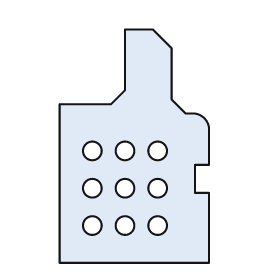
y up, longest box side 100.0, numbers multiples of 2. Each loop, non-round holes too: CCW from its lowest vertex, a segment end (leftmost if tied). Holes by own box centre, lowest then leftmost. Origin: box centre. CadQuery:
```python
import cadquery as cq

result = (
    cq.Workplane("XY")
    .moveTo(-32.0, -50.0)
    .lineTo(32.0, -50.0)
    .lineTo(32.0, -20.0)
    .lineTo(26.0, -20.0)
    .lineTo(26.0, -8.0)
    .lineTo(32.0, -8.0)
    .lineTo(32.0, 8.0)
    .threePointArc((30.0, 12.0), (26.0, 14.0))
    .lineTo(22.0, 14.0)
    .lineTo(16.0, 20.0)
    .lineTo(16.0, 42.0)
    .lineTo(8.0, 50.0)
    .lineTo(-4.0, 50.0)
    .lineTo(-4.0, 24.0)
    .lineTo(-10.0, 18.0)
    .lineTo(-32.0, 18.0)
    .close()
    .moveTo(-18.0, -34.0)
    .circle(4.0)
    .moveTo(-4.0, -34.0)
    .circle(4.0)
    .moveTo(10.0, -34.0)
    .circle(4.0)
    .moveTo(-18.0, -18.0)
    .circle(4.0)
    .moveTo(-4.0, -18.0)
    .circle(4.0)
    .moveTo(10.0, -18.0)
    .circle(4.0)
    .moveTo(-18.0, -2.0)
    .circle(4.0)
    .moveTo(-4.0, -2.0)
    .circle(4.0)
    .moveTo(10.0, -2.0)
    .circle(4.0)
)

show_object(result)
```